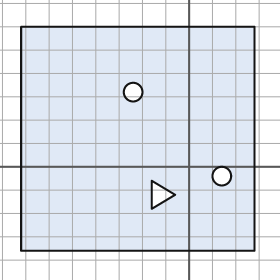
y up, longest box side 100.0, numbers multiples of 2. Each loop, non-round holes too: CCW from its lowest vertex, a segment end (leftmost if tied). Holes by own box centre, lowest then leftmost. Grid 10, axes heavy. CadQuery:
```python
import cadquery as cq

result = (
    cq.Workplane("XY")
    .moveTo(-72.0, -36.0)
    .lineTo(28.0, -36.0)
    .lineTo(28.0, 60.0)
    .lineTo(-72.0, 60.0)
    .close()
    .moveTo(-16.0, -18.0)
    .lineTo(-6.0, -12.0)
    .lineTo(-16.0, -6.0)
    .close()
    .moveTo(14.0, -4.0)
    .circle(4.0)
    .moveTo(-24.0, 32.0)
    .circle(4.0)
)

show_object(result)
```